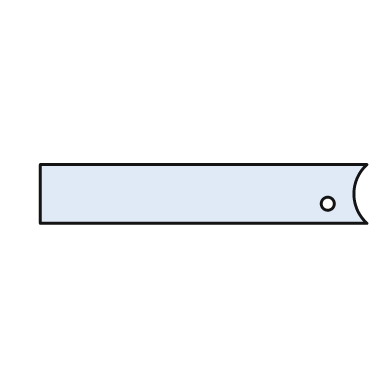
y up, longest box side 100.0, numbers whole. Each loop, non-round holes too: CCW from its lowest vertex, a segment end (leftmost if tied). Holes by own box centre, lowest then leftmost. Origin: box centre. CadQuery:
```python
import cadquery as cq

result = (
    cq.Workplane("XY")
    .moveTo(-50.0, -9.0)
    .lineTo(50.0, -9.0)
    .threePointArc((46.0, 0.0), (50.0, 9.0))
    .lineTo(-50.0, 9.0)
    .close()
    .moveTo(38.0, -3.0)
    .circle(2.0)
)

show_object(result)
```